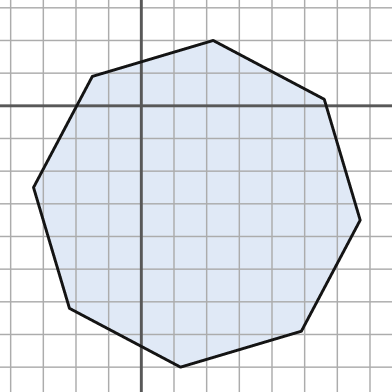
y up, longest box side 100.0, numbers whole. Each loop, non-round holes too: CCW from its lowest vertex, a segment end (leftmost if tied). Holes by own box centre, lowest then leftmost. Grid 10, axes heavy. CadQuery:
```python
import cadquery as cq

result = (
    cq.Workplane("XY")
    .moveTo(12.0, -80.0)
    .lineTo(49.0, -69.0)
    .lineTo(67.0, -35.0)
    .lineTo(56.0, 2.0)
    .lineTo(22.0, 20.0)
    .lineTo(-15.0, 9.0)
    .lineTo(-33.0, -25.0)
    .lineTo(-22.0, -62.0)
    .close()
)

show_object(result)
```